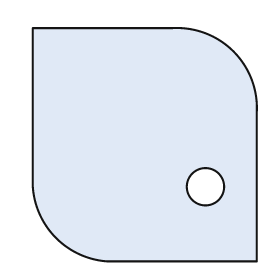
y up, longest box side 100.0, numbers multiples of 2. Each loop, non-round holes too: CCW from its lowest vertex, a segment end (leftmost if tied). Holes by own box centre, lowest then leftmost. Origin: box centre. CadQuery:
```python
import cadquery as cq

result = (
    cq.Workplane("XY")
    .moveTo(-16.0, -50.0)
    .lineTo(48.0, -50.0)
    .lineTo(48.0, 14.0)
    .threePointArc((38.0, 40.0), (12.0, 50.0))
    .lineTo(-48.0, 50.0)
    .lineTo(-48.0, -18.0)
    .threePointArc((-38.0, -40.0), (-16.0, -50.0))
    .close()
    .moveTo(26.0, -18.0)
    .circle(8.0)
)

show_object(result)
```